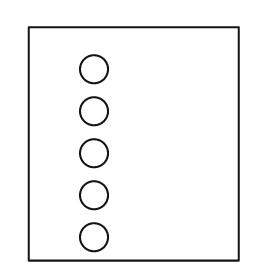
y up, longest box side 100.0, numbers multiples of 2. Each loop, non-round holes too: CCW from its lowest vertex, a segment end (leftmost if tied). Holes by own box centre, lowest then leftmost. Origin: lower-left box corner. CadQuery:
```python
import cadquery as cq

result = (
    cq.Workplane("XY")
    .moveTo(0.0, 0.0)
    .lineTo(90.0, 0.0)
    .lineTo(90.0, 100.0)
    .lineTo(0.0, 100.0)
    .close()
    .moveTo(28.0, 10.0)
    .circle(6.0)
    .moveTo(28.0, 28.0)
    .circle(6.0)
    .moveTo(28.0, 46.0)
    .circle(6.0)
    .moveTo(28.0, 64.0)
    .circle(6.0)
    .moveTo(28.0, 82.0)
    .circle(6.0)
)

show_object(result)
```